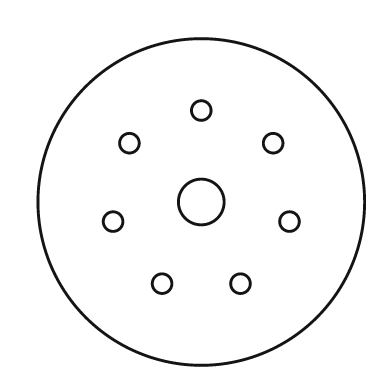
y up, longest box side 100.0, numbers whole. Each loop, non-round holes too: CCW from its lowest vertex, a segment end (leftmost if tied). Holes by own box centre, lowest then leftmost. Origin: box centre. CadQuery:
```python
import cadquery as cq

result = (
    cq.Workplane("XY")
    .moveTo(0.0, 0.0)
    .circle(50.0)
    .moveTo(-12.0, -25.0)
    .circle(3.0)
    .moveTo(12.0, -25.0)
    .circle(3.0)
    .moveTo(-27.0, -6.0)
    .circle(3.0)
    .moveTo(27.0, -6.0)
    .circle(3.0)
    .moveTo(0.0, 0.0)
    .circle(7.0)
    .moveTo(-22.0, 18.0)
    .circle(3.0)
    .moveTo(22.0, 18.0)
    .circle(3.0)
    .moveTo(0.0, 28.0)
    .circle(3.0)
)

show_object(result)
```